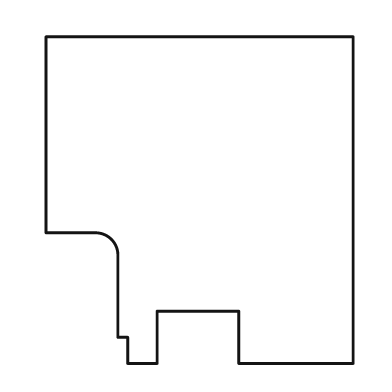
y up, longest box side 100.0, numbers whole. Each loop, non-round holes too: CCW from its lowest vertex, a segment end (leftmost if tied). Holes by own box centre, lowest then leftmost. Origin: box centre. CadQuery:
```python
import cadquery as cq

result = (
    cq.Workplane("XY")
    .moveTo(-22.0, -50.0)
    .lineTo(-13.0, -50.0)
    .lineTo(-13.0, -34.0)
    .lineTo(12.0, -34.0)
    .lineTo(12.0, -50.0)
    .lineTo(47.0, -50.0)
    .lineTo(47.0, 50.0)
    .lineTo(-47.0, 50.0)
    .lineTo(-47.0, -10.0)
    .lineTo(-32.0, -10.0)
    .threePointArc((-27.0, -12.0), (-25.0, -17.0))
    .lineTo(-25.0, -42.0)
    .lineTo(-22.0, -42.0)
    .close()
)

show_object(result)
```